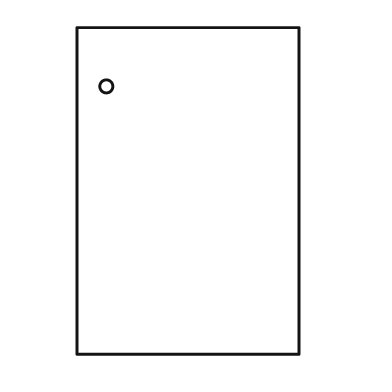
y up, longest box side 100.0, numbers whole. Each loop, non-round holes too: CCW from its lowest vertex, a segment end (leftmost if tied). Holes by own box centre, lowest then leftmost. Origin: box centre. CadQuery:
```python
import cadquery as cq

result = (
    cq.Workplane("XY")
    .moveTo(-34.0, -50.0)
    .lineTo(34.0, -50.0)
    .lineTo(34.0, 50.0)
    .lineTo(-34.0, 50.0)
    .close()
    .moveTo(-25.0, 32.0)
    .circle(2.0)
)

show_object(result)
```